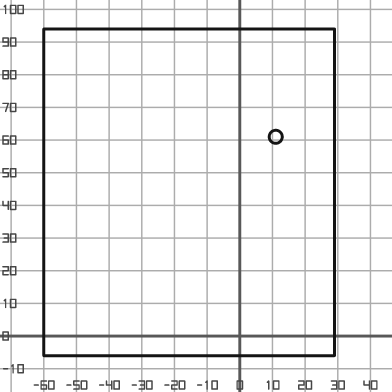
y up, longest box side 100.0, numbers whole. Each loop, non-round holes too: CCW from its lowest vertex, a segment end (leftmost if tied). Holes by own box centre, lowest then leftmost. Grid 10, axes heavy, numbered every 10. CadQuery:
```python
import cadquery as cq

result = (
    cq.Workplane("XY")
    .moveTo(-60.0, -6.0)
    .lineTo(29.0, -6.0)
    .lineTo(29.0, 94.0)
    .lineTo(-60.0, 94.0)
    .close()
    .moveTo(11.0, 61.0)
    .circle(2.0)
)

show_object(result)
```